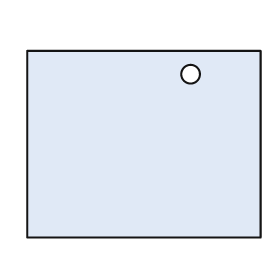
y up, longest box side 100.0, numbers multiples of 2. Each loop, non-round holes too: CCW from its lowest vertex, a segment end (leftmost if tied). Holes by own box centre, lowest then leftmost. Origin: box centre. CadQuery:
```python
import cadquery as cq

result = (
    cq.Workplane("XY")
    .moveTo(-50.0, -40.0)
    .lineTo(50.0, -40.0)
    .lineTo(50.0, 40.0)
    .lineTo(-50.0, 40.0)
    .close()
    .moveTo(20.0, 30.0)
    .circle(4.0)
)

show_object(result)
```